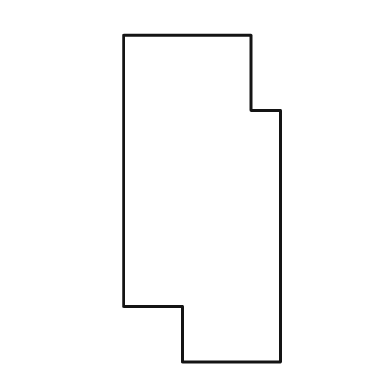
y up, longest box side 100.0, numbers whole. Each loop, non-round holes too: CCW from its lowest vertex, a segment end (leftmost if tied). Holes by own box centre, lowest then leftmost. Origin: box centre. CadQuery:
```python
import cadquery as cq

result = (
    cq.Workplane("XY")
    .moveTo(-6.0, -50.0)
    .lineTo(24.0, -50.0)
    .lineTo(24.0, 27.0)
    .lineTo(15.0, 27.0)
    .lineTo(15.0, 50.0)
    .lineTo(-24.0, 50.0)
    .lineTo(-24.0, -33.0)
    .lineTo(-6.0, -33.0)
    .close()
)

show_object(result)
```